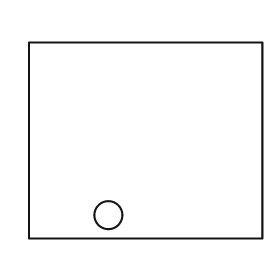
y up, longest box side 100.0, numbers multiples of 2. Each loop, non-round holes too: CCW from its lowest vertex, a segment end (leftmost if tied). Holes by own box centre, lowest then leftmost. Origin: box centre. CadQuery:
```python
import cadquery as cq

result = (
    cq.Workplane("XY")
    .moveTo(-50.0, -42.0)
    .lineTo(50.0, -42.0)
    .lineTo(50.0, 42.0)
    .lineTo(-50.0, 42.0)
    .close()
    .moveTo(-16.0, -32.0)
    .circle(6.0)
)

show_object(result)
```